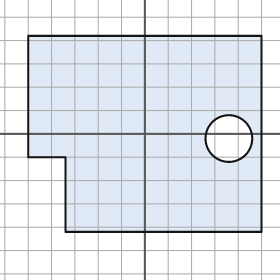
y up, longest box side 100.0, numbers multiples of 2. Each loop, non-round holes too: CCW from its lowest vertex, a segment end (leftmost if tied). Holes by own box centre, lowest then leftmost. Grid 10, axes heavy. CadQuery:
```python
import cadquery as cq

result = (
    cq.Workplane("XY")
    .moveTo(-34.0, -42.0)
    .lineTo(50.0, -42.0)
    .lineTo(50.0, 42.0)
    .lineTo(-50.0, 42.0)
    .lineTo(-50.0, -10.0)
    .lineTo(-34.0, -10.0)
    .close()
    .moveTo(36.0, -2.0)
    .circle(10.0)
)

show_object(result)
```